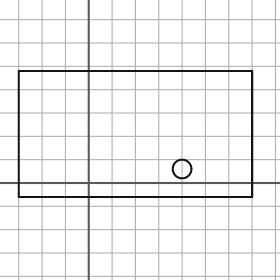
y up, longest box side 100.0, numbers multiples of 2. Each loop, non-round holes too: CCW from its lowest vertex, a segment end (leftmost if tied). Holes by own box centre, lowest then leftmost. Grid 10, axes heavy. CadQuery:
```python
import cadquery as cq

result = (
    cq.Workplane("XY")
    .moveTo(-30.0, -6.0)
    .lineTo(70.0, -6.0)
    .lineTo(70.0, 48.0)
    .lineTo(-30.0, 48.0)
    .close()
    .moveTo(40.0, 6.0)
    .circle(4.0)
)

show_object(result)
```